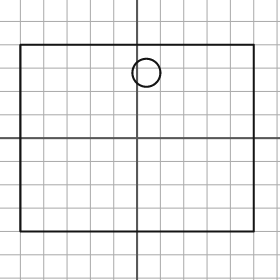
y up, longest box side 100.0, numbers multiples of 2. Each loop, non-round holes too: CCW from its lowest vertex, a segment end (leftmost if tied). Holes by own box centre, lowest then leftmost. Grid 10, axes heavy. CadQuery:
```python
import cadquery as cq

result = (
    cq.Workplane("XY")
    .moveTo(-50.0, -40.0)
    .lineTo(50.0, -40.0)
    .lineTo(50.0, 40.0)
    .lineTo(-50.0, 40.0)
    .close()
    .moveTo(4.0, 28.0)
    .circle(6.0)
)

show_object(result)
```